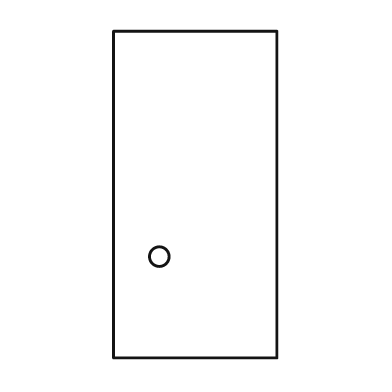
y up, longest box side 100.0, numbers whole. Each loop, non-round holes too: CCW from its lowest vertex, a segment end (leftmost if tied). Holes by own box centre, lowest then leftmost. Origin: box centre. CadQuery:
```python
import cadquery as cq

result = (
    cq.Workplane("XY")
    .moveTo(-25.0, -50.0)
    .lineTo(25.0, -50.0)
    .lineTo(25.0, 50.0)
    .lineTo(-25.0, 50.0)
    .close()
    .moveTo(-11.0, -19.0)
    .circle(3.0)
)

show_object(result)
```